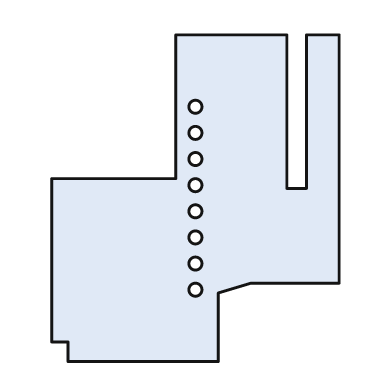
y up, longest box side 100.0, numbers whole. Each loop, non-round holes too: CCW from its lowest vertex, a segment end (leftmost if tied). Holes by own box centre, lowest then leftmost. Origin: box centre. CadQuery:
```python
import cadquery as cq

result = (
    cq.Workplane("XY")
    .moveTo(-39.0, -50.0)
    .lineTo(7.0, -50.0)
    .lineTo(7.0, -29.0)
    .lineTo(17.0, -26.0)
    .lineTo(44.0, -26.0)
    .lineTo(44.0, 50.0)
    .lineTo(34.0, 50.0)
    .lineTo(34.0, 3.0)
    .lineTo(28.0, 3.0)
    .lineTo(28.0, 50.0)
    .lineTo(-6.0, 50.0)
    .lineTo(-6.0, 6.0)
    .lineTo(-44.0, 6.0)
    .lineTo(-44.0, -44.0)
    .lineTo(-39.0, -44.0)
    .close()
    .moveTo(0.0, -28.0)
    .circle(2.0)
    .moveTo(0.0, -20.0)
    .circle(2.0)
    .moveTo(0.0, -12.0)
    .circle(2.0)
    .moveTo(0.0, -4.0)
    .circle(2.0)
    .moveTo(0.0, 4.0)
    .circle(2.0)
    .moveTo(0.0, 12.0)
    .circle(2.0)
    .moveTo(0.0, 20.0)
    .circle(2.0)
    .moveTo(0.0, 28.0)
    .circle(2.0)
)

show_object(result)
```